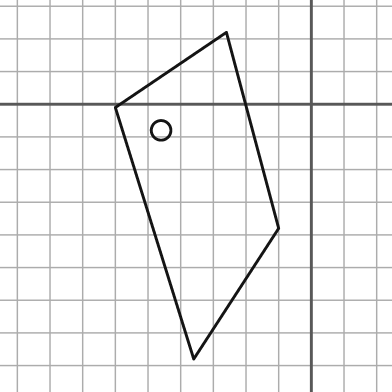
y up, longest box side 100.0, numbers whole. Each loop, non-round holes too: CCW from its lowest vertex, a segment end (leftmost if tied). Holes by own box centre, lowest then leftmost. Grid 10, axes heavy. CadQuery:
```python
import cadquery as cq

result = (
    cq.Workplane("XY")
    .moveTo(-36.0, -78.0)
    .lineTo(-10.0, -38.0)
    .lineTo(-26.0, 22.0)
    .lineTo(-60.0, -1.0)
    .close()
    .moveTo(-46.0, -8.0)
    .circle(3.0)
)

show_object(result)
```